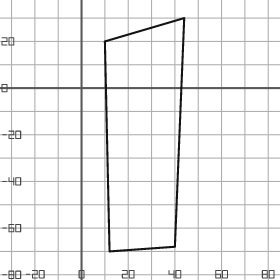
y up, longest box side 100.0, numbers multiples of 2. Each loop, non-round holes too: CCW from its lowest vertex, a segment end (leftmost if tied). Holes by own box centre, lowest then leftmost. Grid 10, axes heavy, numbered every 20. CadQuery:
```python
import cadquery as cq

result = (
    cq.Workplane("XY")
    .moveTo(12.0, -70.0)
    .lineTo(40.0, -68.0)
    .lineTo(44.0, 30.0)
    .lineTo(10.0, 20.0)
    .close()
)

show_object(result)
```